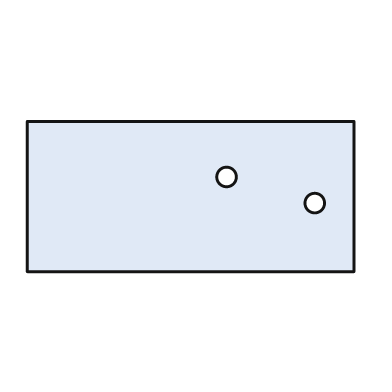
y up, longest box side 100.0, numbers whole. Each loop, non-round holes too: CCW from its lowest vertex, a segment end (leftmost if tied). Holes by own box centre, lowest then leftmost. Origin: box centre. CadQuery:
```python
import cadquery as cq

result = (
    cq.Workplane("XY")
    .moveTo(-50.0, -23.0)
    .lineTo(50.0, -23.0)
    .lineTo(50.0, 23.0)
    .lineTo(-50.0, 23.0)
    .close()
    .moveTo(38.0, -2.0)
    .circle(3.0)
    .moveTo(11.0, 6.0)
    .circle(3.0)
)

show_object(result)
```